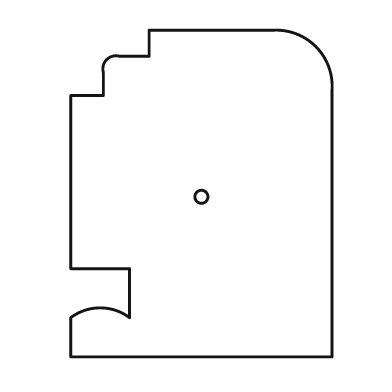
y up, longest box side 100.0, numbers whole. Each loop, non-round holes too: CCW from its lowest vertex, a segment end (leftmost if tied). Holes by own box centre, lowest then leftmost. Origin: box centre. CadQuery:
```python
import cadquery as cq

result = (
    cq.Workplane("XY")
    .moveTo(-40.0, -50.0)
    .lineTo(40.0, -50.0)
    .lineTo(40.0, 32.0)
    .threePointArc((35.0, 45.0), (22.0, 50.0))
    .lineTo(-16.0, 50.0)
    .lineTo(-16.0, 42.0)
    .lineTo(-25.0, 42.0)
    .threePointArc((-29.0, 41.0), (-30.0, 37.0))
    .lineTo(-30.0, 30.0)
    .lineTo(-40.0, 30.0)
    .lineTo(-40.0, -23.0)
    .lineTo(-22.0, -23.0)
    .lineTo(-22.0, -38.0)
    .threePointArc((-31.0, -35.0), (-40.0, -38.0))
    .close()
    .moveTo(0.0, -1.0)
    .circle(2.0)
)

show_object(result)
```